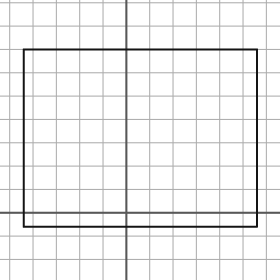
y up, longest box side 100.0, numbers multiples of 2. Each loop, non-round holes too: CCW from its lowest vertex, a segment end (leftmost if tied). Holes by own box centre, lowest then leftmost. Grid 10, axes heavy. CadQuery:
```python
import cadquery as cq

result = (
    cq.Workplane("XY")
    .moveTo(-44.0, -6.0)
    .lineTo(56.0, -6.0)
    .lineTo(56.0, 70.0)
    .lineTo(-44.0, 70.0)
    .close()
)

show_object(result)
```